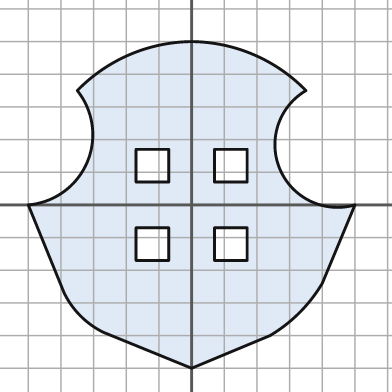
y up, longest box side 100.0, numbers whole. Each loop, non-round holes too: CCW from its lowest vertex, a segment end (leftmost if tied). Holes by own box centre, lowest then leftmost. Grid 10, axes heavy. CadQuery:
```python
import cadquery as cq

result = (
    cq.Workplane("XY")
    .moveTo(0.0, -50.0)
    .lineTo(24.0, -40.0)
    .threePointArc((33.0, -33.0), (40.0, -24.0))
    .lineTo(50.0, 0.0)
    .threePointArc((27.0, 11.0), (35.0, 35.0))
    .threePointArc((19.0, 46.0), (0.0, 50.0))
    .threePointArc((-19.0, 46.0), (-35.0, 35.0))
    .threePointArc((-32.0, 13.0), (-50.0, 0.0))
    .lineTo(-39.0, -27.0)
    .threePointArc((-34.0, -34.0), (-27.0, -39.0))
    .close()
    .moveTo(-17.0, -17.0)
    .lineTo(-7.0, -17.0)
    .lineTo(-7.0, -7.0)
    .lineTo(-17.0, -7.0)
    .close()
    .moveTo(7.0, -17.0)
    .lineTo(17.0, -17.0)
    .lineTo(17.0, -7.0)
    .lineTo(7.0, -7.0)
    .close()
    .moveTo(-17.0, 7.0)
    .lineTo(-7.0, 7.0)
    .lineTo(-7.0, 17.0)
    .lineTo(-17.0, 17.0)
    .close()
    .moveTo(7.0, 7.0)
    .lineTo(17.0, 7.0)
    .lineTo(17.0, 17.0)
    .lineTo(7.0, 17.0)
    .close()
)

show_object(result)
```